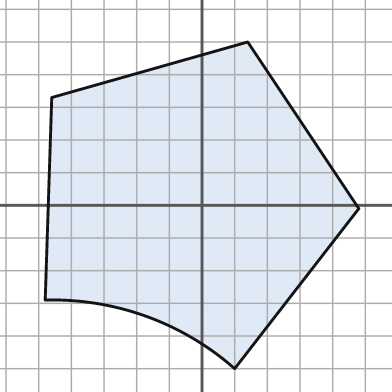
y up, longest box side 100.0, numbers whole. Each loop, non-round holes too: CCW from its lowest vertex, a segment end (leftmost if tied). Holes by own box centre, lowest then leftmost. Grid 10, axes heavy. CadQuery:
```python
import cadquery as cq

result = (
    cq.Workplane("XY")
    .moveTo(10.0, -50.0)
    .lineTo(48.0, -1.0)
    .lineTo(14.0, 50.0)
    .lineTo(-46.0, 33.0)
    .lineTo(-48.0, -29.0)
    .threePointArc((-17.0, -34.0), (10.0, -50.0))
    .close()
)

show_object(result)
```